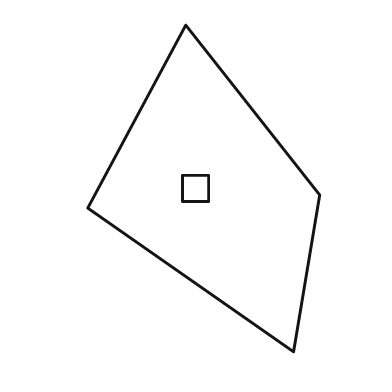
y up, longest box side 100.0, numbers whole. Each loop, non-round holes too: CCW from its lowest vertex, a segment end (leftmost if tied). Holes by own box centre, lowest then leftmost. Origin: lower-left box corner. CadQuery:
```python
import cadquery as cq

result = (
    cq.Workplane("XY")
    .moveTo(63.0, 0.0)
    .lineTo(71.0, 48.0)
    .lineTo(30.0, 100.0)
    .lineTo(0.0, 44.0)
    .close()
    .moveTo(29.0, 46.0)
    .lineTo(37.0, 46.0)
    .lineTo(37.0, 54.0)
    .lineTo(29.0, 54.0)
    .close()
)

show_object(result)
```